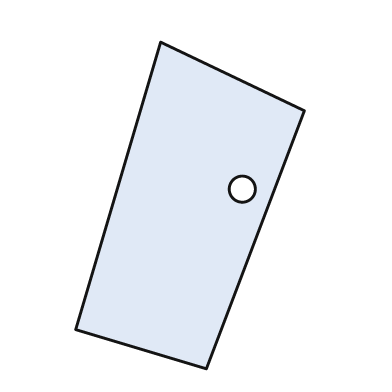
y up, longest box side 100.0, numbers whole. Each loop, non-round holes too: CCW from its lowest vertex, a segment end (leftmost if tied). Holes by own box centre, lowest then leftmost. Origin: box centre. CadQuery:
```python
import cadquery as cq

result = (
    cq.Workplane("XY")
    .moveTo(5.0, -50.0)
    .lineTo(35.0, 29.0)
    .lineTo(-9.0, 50.0)
    .lineTo(-35.0, -38.0)
    .close()
    .moveTo(16.0, 5.0)
    .circle(4.0)
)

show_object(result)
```